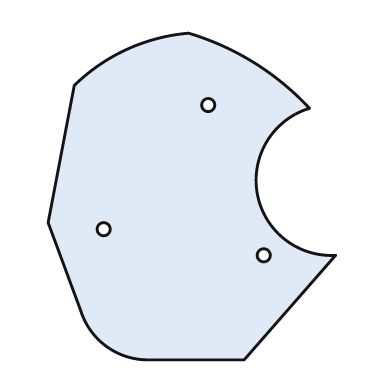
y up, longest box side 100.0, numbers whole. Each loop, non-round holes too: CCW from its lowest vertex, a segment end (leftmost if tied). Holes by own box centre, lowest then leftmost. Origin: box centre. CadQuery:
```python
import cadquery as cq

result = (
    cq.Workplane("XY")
    .moveTo(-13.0, -50.0)
    .lineTo(16.0, -50.0)
    .lineTo(44.0, -18.0)
    .threePointArc((20.0, 1.0), (36.0, 27.0))
    .threePointArc((19.0, 41.0), (-1.0, 50.0))
    .threePointArc((-20.0, 45.0), (-36.0, 34.0))
    .lineTo(-44.0, -8.0)
    .lineTo(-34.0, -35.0)
    .threePointArc((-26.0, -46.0), (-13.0, -50.0))
    .close()
    .moveTo(22.0, -18.0)
    .circle(2.0)
    .moveTo(-27.0, -10.0)
    .circle(2.0)
    .moveTo(5.0, 28.0)
    .circle(2.0)
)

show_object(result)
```